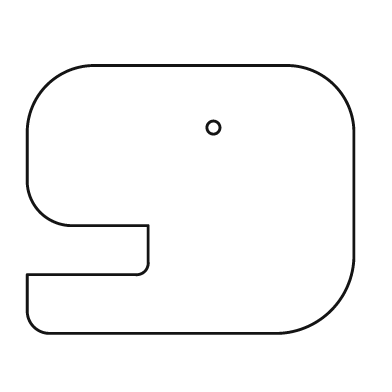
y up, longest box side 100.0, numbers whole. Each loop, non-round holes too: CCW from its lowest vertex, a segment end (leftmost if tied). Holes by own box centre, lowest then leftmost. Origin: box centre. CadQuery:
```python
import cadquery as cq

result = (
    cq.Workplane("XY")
    .moveTo(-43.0, -41.0)
    .lineTo(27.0, -41.0)
    .threePointArc((43.0, -34.0), (50.0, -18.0))
    .lineTo(50.0, 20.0)
    .threePointArc((44.0, 35.0), (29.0, 41.0))
    .lineTo(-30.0, 41.0)
    .threePointArc((-44.0, 35.0), (-50.0, 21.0))
    .lineTo(-50.0, 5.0)
    .threePointArc((-46.0, -4.0), (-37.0, -8.0))
    .lineTo(-13.0, -8.0)
    .lineTo(-13.0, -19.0)
    .threePointArc((-14.0, -22.0), (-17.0, -23.0))
    .lineTo(-50.0, -23.0)
    .lineTo(-50.0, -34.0)
    .threePointArc((-48.0, -39.0), (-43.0, -41.0))
    .close()
    .moveTo(7.0, 22.0)
    .circle(2.0)
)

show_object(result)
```